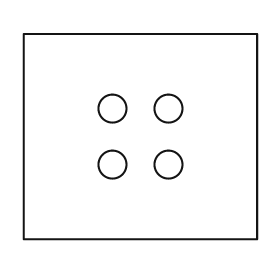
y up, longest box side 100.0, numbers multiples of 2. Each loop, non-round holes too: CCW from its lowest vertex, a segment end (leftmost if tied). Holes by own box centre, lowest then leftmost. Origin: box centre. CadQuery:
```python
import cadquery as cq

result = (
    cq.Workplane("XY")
    .moveTo(-50.0, -44.0)
    .lineTo(50.0, -44.0)
    .lineTo(50.0, 44.0)
    .lineTo(-50.0, 44.0)
    .close()
    .moveTo(-12.0, -12.0)
    .circle(6.0)
    .moveTo(12.0, -12.0)
    .circle(6.0)
    .moveTo(-12.0, 12.0)
    .circle(6.0)
    .moveTo(12.0, 12.0)
    .circle(6.0)
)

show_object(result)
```